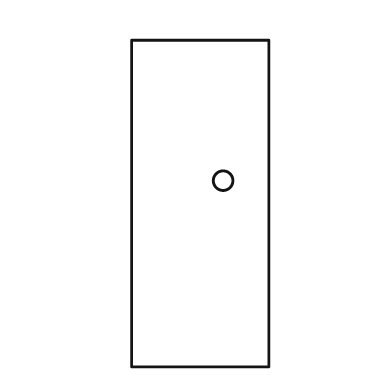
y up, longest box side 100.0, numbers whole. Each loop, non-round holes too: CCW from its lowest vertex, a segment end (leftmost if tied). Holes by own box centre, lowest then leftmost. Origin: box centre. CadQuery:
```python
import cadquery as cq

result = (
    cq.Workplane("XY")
    .moveTo(-21.0, -50.0)
    .lineTo(21.0, -50.0)
    .lineTo(21.0, 50.0)
    .lineTo(-21.0, 50.0)
    .close()
    .moveTo(7.0, 7.0)
    .circle(3.0)
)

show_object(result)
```